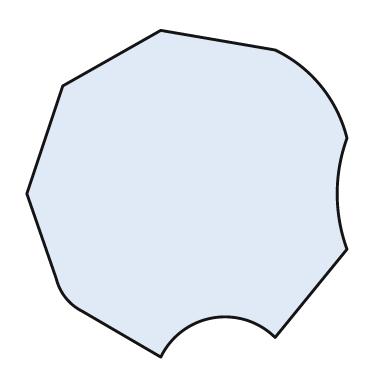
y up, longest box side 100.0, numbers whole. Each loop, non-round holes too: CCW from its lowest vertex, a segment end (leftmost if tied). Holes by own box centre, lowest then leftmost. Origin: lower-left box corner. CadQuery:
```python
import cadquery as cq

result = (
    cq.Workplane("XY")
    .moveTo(41.0, 0.0)
    .threePointArc((57.0, 12.0), (76.0, 6.0))
    .lineTo(98.0, 33.0)
    .threePointArc((95.0, 50.0), (98.0, 67.0))
    .threePointArc((90.0, 83.0), (76.0, 94.0))
    .lineTo(41.0, 100.0)
    .lineTo(11.0, 83.0)
    .lineTo(0.0, 50.0)
    .lineTo(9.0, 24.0)
    .threePointArc((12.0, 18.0), (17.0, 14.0))
    .close()
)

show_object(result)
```